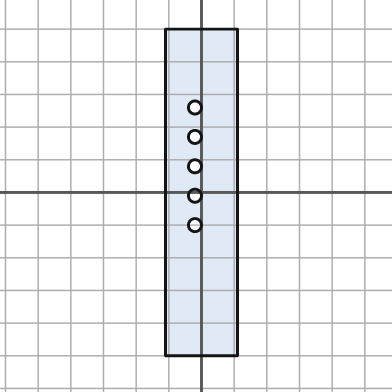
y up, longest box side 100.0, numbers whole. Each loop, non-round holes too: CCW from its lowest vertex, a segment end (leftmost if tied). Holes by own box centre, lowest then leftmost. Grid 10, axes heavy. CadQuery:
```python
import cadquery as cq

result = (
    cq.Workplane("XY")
    .moveTo(-11.0, -50.0)
    .lineTo(11.0, -50.0)
    .lineTo(11.0, 50.0)
    .lineTo(-11.0, 50.0)
    .close()
    .moveTo(-2.0, -10.0)
    .circle(2.0)
    .moveTo(-2.0, -1.0)
    .circle(2.0)
    .moveTo(-2.0, 8.0)
    .circle(2.0)
    .moveTo(-2.0, 17.0)
    .circle(2.0)
    .moveTo(-2.0, 26.0)
    .circle(2.0)
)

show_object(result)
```